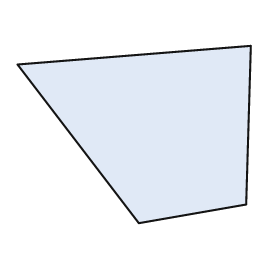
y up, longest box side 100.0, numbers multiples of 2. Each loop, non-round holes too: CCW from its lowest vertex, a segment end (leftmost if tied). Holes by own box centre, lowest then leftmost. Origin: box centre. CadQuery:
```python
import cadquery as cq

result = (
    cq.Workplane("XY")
    .moveTo(2.0, -38.0)
    .lineTo(48.0, -30.0)
    .lineTo(50.0, 38.0)
    .lineTo(-50.0, 30.0)
    .close()
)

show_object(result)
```